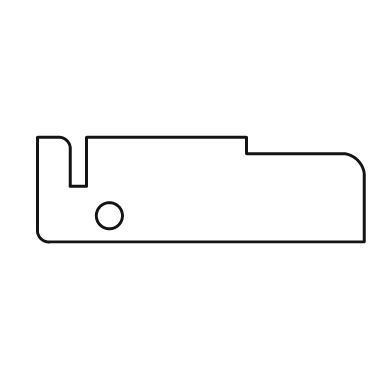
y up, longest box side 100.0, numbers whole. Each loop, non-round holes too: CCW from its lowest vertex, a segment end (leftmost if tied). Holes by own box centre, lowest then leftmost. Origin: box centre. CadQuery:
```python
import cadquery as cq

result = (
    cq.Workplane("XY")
    .moveTo(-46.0, -16.0)
    .lineTo(50.0, -16.0)
    .lineTo(50.0, 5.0)
    .threePointArc((48.0, 9.0), (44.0, 11.0))
    .lineTo(14.0, 11.0)
    .lineTo(14.0, 16.0)
    .lineTo(-35.0, 16.0)
    .lineTo(-35.0, 1.0)
    .lineTo(-40.0, 1.0)
    .lineTo(-40.0, 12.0)
    .threePointArc((-41.0, 15.0), (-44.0, 16.0))
    .lineTo(-50.0, 16.0)
    .lineTo(-50.0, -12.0)
    .threePointArc((-49.0, -15.0), (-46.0, -16.0))
    .close()
    .moveTo(-28.0, -8.0)
    .circle(4.0)
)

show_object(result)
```